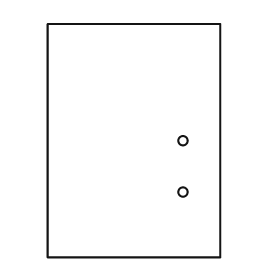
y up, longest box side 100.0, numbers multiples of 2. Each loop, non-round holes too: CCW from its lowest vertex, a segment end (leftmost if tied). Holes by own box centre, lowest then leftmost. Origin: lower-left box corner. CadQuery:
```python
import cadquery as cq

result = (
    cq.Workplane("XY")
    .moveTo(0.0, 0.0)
    .lineTo(74.0, 0.0)
    .lineTo(74.0, 100.0)
    .lineTo(0.0, 100.0)
    .close()
    .moveTo(58.0, 28.0)
    .circle(2.0)
    .moveTo(58.0, 50.0)
    .circle(2.0)
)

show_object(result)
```